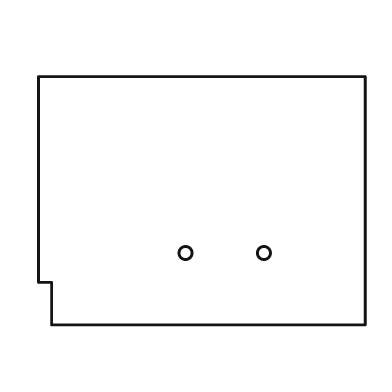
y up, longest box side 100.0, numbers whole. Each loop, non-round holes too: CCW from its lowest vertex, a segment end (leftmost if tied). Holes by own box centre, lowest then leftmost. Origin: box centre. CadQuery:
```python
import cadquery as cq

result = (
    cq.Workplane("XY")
    .moveTo(-46.0, -38.0)
    .lineTo(50.0, -38.0)
    .lineTo(50.0, 38.0)
    .lineTo(-50.0, 38.0)
    .lineTo(-50.0, -25.0)
    .lineTo(-46.0, -25.0)
    .close()
    .moveTo(-5.0, -16.0)
    .circle(2.0)
    .moveTo(19.0, -16.0)
    .circle(2.0)
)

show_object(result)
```